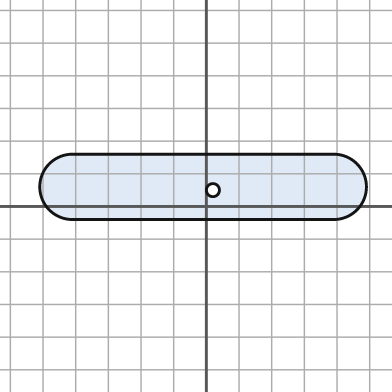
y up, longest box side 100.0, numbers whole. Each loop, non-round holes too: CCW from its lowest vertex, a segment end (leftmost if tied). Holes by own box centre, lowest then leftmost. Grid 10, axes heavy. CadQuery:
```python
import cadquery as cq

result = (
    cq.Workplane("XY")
    .moveTo(-41.0, -4.0)
    .lineTo(39.0, -4.0)
    .threePointArc((49.0, 6.0), (39.0, 16.0))
    .lineTo(-41.0, 16.0)
    .threePointArc((-51.0, 6.0), (-41.0, -4.0))
    .close()
    .moveTo(2.0, 5.0)
    .circle(2.0)
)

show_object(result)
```